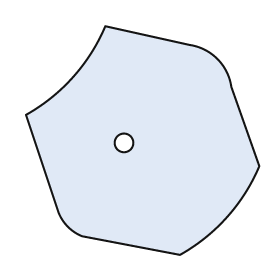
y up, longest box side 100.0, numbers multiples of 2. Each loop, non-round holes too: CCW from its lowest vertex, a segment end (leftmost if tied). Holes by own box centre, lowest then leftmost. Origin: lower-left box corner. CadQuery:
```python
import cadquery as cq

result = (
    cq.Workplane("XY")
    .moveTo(66.0, 0.0)
    .threePointArc((86.0, 16.0), (100.0, 38.0))
    .lineTo(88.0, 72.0)
    .threePointArc((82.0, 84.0), (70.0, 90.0))
    .lineTo(34.0, 98.0)
    .threePointArc((20.0, 76.0), (0.0, 60.0))
    .lineTo(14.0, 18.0)
    .threePointArc((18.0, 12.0), (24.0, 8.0))
    .close()
    .moveTo(42.0, 48.0)
    .circle(4.0)
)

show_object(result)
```